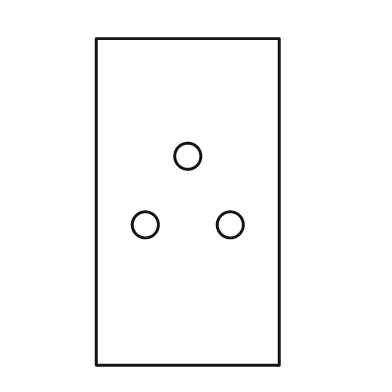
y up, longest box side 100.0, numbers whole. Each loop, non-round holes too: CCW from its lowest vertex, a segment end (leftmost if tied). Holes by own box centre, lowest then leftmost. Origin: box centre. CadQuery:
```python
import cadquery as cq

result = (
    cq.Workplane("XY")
    .moveTo(-28.0, -50.0)
    .lineTo(28.0, -50.0)
    .lineTo(28.0, 50.0)
    .lineTo(-28.0, 50.0)
    .close()
    .moveTo(-13.0, -7.0)
    .circle(4.0)
    .moveTo(13.0, -7.0)
    .circle(4.0)
    .moveTo(0.0, 14.0)
    .circle(4.0)
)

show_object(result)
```